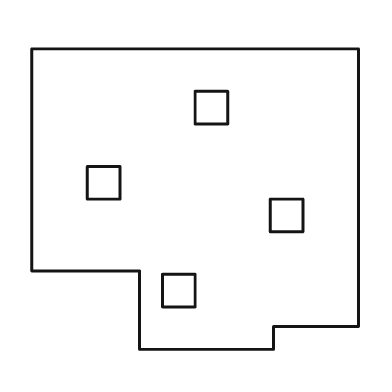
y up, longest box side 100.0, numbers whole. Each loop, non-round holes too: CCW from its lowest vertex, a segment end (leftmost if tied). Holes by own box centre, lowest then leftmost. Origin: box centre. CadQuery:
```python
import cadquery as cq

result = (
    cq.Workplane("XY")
    .moveTo(-17.0, -46.0)
    .lineTo(24.0, -46.0)
    .lineTo(24.0, -39.0)
    .lineTo(50.0, -39.0)
    .lineTo(50.0, 46.0)
    .lineTo(-50.0, 46.0)
    .lineTo(-50.0, -22.0)
    .lineTo(-17.0, -22.0)
    .close()
    .moveTo(-10.0, -33.0)
    .lineTo(0.0, -33.0)
    .lineTo(0.0, -23.0)
    .lineTo(-10.0, -23.0)
    .close()
    .moveTo(23.0, -10.0)
    .lineTo(33.0, -10.0)
    .lineTo(33.0, 0.0)
    .lineTo(23.0, 0.0)
    .close()
    .moveTo(-33.0, 0.0)
    .lineTo(-23.0, 0.0)
    .lineTo(-23.0, 10.0)
    .lineTo(-33.0, 10.0)
    .close()
    .moveTo(0.0, 23.0)
    .lineTo(10.0, 23.0)
    .lineTo(10.0, 33.0)
    .lineTo(0.0, 33.0)
    .close()
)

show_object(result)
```